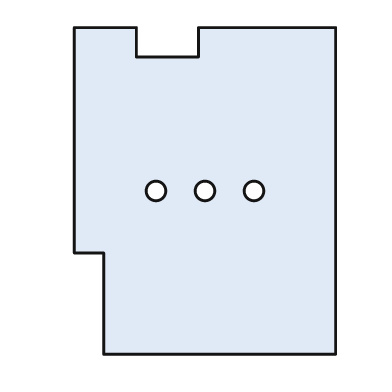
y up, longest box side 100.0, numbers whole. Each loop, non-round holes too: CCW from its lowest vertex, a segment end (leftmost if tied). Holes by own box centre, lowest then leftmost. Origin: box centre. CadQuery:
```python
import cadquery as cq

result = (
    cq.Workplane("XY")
    .moveTo(-31.0, -50.0)
    .lineTo(40.0, -50.0)
    .lineTo(40.0, 50.0)
    .lineTo(-2.0, 50.0)
    .lineTo(-2.0, 41.0)
    .lineTo(-21.0, 41.0)
    .lineTo(-21.0, 50.0)
    .lineTo(-40.0, 50.0)
    .lineTo(-40.0, -19.0)
    .lineTo(-31.0, -19.0)
    .close()
    .moveTo(-15.0, 0.0)
    .circle(3.0)
    .moveTo(0.0, 0.0)
    .circle(3.0)
    .moveTo(15.0, 0.0)
    .circle(3.0)
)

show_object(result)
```